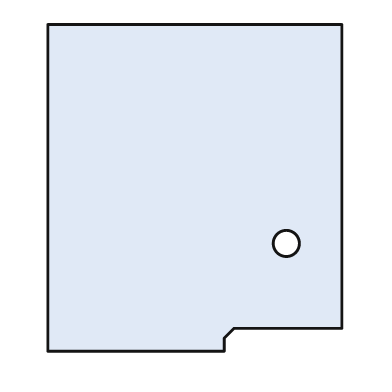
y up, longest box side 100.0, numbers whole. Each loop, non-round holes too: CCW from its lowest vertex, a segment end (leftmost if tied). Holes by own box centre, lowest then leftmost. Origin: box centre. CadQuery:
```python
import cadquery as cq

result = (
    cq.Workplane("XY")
    .moveTo(-45.0, -50.0)
    .lineTo(9.0, -50.0)
    .lineTo(9.0, -46.0)
    .lineTo(12.0, -43.0)
    .lineTo(45.0, -43.0)
    .lineTo(45.0, 50.0)
    .lineTo(-45.0, 50.0)
    .close()
    .moveTo(28.0, -17.0)
    .circle(4.0)
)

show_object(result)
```